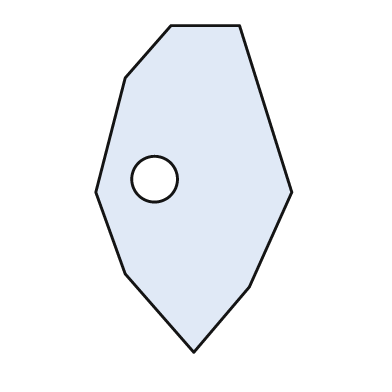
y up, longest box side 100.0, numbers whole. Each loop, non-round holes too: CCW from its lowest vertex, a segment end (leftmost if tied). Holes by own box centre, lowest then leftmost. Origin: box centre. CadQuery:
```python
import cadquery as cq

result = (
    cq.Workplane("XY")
    .moveTo(0.0, -50.0)
    .lineTo(17.0, -30.0)
    .lineTo(30.0, -1.0)
    .lineTo(14.0, 50.0)
    .lineTo(-7.0, 50.0)
    .lineTo(-21.0, 34.0)
    .lineTo(-30.0, -1.0)
    .lineTo(-21.0, -26.0)
    .close()
    .moveTo(-12.0, 3.0)
    .circle(7.0)
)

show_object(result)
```